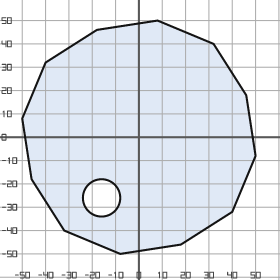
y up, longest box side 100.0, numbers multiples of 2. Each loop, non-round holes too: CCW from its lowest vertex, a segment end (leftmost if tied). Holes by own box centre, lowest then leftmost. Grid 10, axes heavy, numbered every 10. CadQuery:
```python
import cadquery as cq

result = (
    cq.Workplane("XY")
    .moveTo(-8.0, -50.0)
    .lineTo(18.0, -46.0)
    .lineTo(40.0, -32.0)
    .lineTo(50.0, -8.0)
    .lineTo(46.0, 18.0)
    .lineTo(32.0, 40.0)
    .lineTo(8.0, 50.0)
    .lineTo(-18.0, 46.0)
    .lineTo(-40.0, 32.0)
    .lineTo(-50.0, 8.0)
    .lineTo(-46.0, -18.0)
    .lineTo(-32.0, -40.0)
    .close()
    .moveTo(-16.0, -26.0)
    .circle(8.0)
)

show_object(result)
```